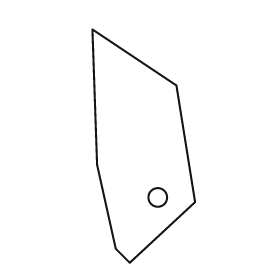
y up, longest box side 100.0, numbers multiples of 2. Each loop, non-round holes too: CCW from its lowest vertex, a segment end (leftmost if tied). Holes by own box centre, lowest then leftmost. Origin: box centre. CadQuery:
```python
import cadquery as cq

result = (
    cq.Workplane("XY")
    .moveTo(-6.0, -50.0)
    .lineTo(22.0, -24.0)
    .lineTo(14.0, 26.0)
    .lineTo(-22.0, 50.0)
    .lineTo(-20.0, -8.0)
    .lineTo(-12.0, -44.0)
    .close()
    .moveTo(6.0, -22.0)
    .circle(4.0)
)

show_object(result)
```